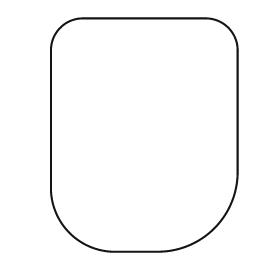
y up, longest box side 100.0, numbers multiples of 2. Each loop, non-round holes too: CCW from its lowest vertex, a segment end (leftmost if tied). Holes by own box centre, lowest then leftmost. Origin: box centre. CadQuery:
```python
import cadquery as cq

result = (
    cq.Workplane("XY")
    .moveTo(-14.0, -50.0)
    .lineTo(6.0, -50.0)
    .threePointArc((30.0, -40.0), (40.0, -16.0))
    .lineTo(40.0, 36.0)
    .threePointArc((36.0, 46.0), (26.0, 50.0))
    .lineTo(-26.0, 50.0)
    .threePointArc((-36.0, 46.0), (-40.0, 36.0))
    .lineTo(-40.0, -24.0)
    .threePointArc((-32.0, -42.0), (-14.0, -50.0))
    .close()
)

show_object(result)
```